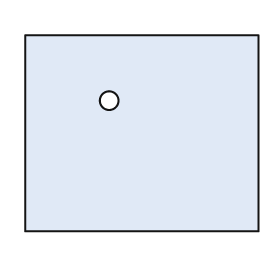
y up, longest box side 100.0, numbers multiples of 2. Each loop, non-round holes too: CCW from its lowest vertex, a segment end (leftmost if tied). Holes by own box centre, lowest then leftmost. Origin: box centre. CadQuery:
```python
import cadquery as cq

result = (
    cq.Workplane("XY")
    .moveTo(-50.0, -42.0)
    .lineTo(50.0, -42.0)
    .lineTo(50.0, 42.0)
    .lineTo(-50.0, 42.0)
    .close()
    .moveTo(-14.0, 14.0)
    .circle(4.0)
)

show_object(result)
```